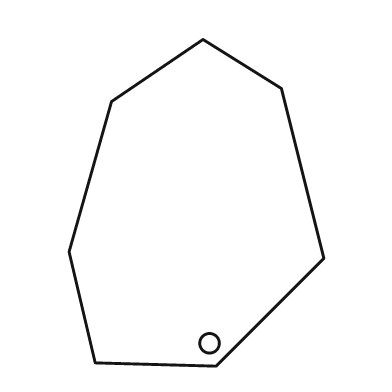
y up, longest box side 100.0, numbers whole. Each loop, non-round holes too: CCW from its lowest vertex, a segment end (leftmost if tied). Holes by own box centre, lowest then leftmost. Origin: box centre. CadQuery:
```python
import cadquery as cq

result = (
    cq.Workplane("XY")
    .moveTo(6.0, -50.0)
    .lineTo(39.0, -17.0)
    .lineTo(26.0, 35.0)
    .lineTo(2.0, 50.0)
    .lineTo(-26.0, 31.0)
    .lineTo(-39.0, -15.0)
    .lineTo(-31.0, -49.0)
    .close()
    .moveTo(4.0, -43.0)
    .circle(3.0)
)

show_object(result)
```